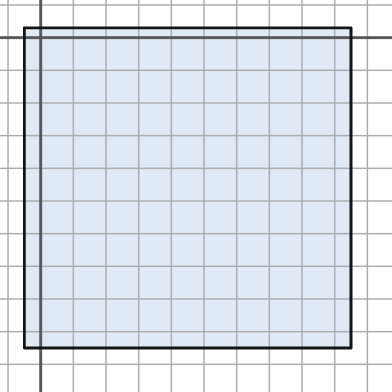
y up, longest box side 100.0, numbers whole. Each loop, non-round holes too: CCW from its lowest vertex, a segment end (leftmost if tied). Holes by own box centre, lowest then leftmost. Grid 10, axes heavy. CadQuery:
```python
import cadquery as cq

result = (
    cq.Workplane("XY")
    .moveTo(-5.0, -95.0)
    .lineTo(95.0, -95.0)
    .lineTo(95.0, 3.0)
    .lineTo(-5.0, 3.0)
    .close()
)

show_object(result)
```